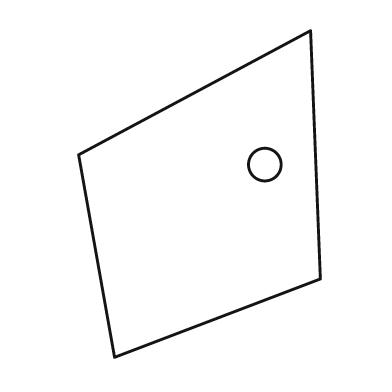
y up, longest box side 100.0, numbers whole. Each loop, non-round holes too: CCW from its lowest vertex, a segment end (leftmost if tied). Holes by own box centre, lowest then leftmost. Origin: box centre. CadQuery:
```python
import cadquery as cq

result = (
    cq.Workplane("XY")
    .moveTo(-26.0, -50.0)
    .lineTo(37.0, -26.0)
    .lineTo(34.0, 50.0)
    .lineTo(-37.0, 12.0)
    .close()
    .moveTo(20.0, 9.0)
    .circle(5.0)
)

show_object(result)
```